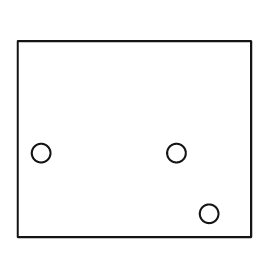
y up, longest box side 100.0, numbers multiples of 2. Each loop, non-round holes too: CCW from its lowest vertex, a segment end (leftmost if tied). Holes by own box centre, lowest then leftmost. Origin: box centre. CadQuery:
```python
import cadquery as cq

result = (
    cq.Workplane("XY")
    .moveTo(-50.0, -42.0)
    .lineTo(50.0, -42.0)
    .lineTo(50.0, 42.0)
    .lineTo(-50.0, 42.0)
    .close()
    .moveTo(32.0, -32.0)
    .circle(4.0)
    .moveTo(-40.0, -6.0)
    .circle(4.0)
    .moveTo(18.0, -6.0)
    .circle(4.0)
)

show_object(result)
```